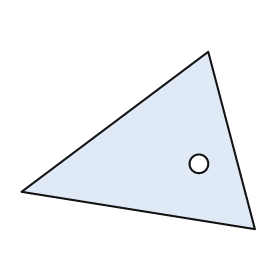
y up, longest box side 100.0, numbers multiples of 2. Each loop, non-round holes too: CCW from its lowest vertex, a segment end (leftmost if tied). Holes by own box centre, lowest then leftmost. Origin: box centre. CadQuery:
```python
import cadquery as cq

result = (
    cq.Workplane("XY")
    .moveTo(50.0, -38.0)
    .lineTo(30.0, 38.0)
    .lineTo(-50.0, -22.0)
    .close()
    .moveTo(26.0, -10.0)
    .circle(4.0)
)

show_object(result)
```